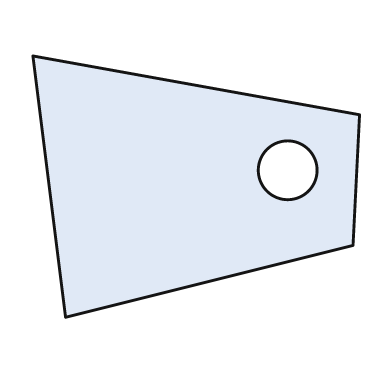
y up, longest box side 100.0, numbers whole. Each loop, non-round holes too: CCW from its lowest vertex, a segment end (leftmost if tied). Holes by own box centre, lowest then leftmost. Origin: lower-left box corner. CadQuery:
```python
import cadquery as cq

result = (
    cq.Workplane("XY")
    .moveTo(10.0, 0.0)
    .lineTo(98.0, 22.0)
    .lineTo(100.0, 62.0)
    .lineTo(0.0, 80.0)
    .close()
    .moveTo(78.0, 45.0)
    .circle(9.0)
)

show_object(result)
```